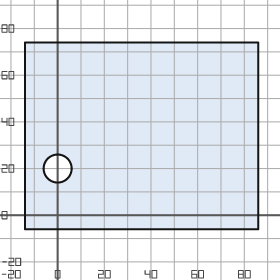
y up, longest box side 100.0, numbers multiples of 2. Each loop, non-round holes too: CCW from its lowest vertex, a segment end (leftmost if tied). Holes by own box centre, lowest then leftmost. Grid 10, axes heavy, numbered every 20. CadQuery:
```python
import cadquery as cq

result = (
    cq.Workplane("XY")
    .moveTo(-14.0, -6.0)
    .lineTo(86.0, -6.0)
    .lineTo(86.0, 74.0)
    .lineTo(-14.0, 74.0)
    .close()
    .moveTo(0.0, 20.0)
    .circle(6.0)
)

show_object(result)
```